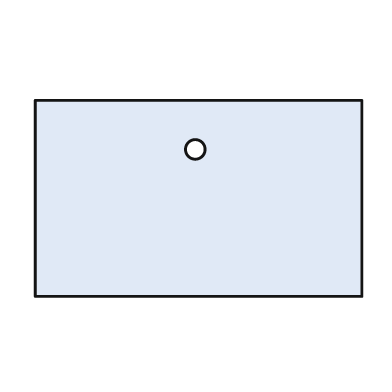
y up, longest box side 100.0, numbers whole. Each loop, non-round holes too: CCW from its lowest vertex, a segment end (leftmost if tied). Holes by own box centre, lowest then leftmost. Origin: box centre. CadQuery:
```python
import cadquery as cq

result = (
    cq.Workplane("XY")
    .moveTo(-50.0, -30.0)
    .lineTo(50.0, -30.0)
    .lineTo(50.0, 30.0)
    .lineTo(-50.0, 30.0)
    .close()
    .moveTo(-1.0, 15.0)
    .circle(3.0)
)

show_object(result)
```